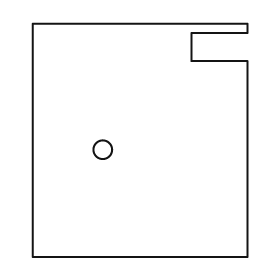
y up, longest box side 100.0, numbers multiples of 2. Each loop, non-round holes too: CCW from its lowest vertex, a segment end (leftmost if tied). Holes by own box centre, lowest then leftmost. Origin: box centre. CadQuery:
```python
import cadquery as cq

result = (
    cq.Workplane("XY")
    .moveTo(-46.0, -50.0)
    .lineTo(46.0, -50.0)
    .lineTo(46.0, 34.0)
    .lineTo(22.0, 34.0)
    .lineTo(22.0, 46.0)
    .lineTo(46.0, 46.0)
    .lineTo(46.0, 50.0)
    .lineTo(-46.0, 50.0)
    .close()
    .moveTo(-16.0, -4.0)
    .circle(4.0)
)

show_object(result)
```